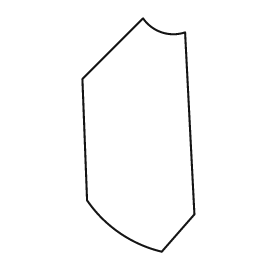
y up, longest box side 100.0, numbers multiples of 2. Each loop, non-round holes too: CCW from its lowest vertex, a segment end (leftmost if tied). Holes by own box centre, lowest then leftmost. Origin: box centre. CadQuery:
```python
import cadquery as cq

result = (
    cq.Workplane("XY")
    .moveTo(10.0, -50.0)
    .lineTo(24.0, -34.0)
    .lineTo(20.0, 44.0)
    .threePointArc((10.0, 44.0), (2.0, 50.0))
    .lineTo(-24.0, 24.0)
    .lineTo(-22.0, -28.0)
    .threePointArc((-8.0, -42.0), (10.0, -50.0))
    .close()
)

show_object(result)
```